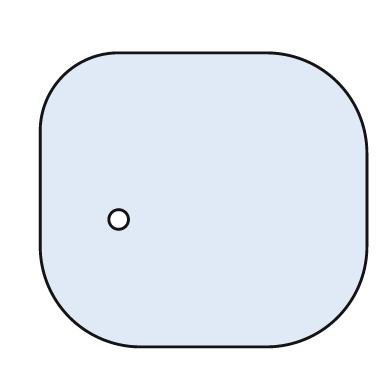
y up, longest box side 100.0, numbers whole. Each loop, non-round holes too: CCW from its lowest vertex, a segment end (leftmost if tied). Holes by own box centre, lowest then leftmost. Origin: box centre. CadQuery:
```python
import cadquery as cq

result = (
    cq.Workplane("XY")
    .moveTo(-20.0, -45.0)
    .lineTo(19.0, -45.0)
    .threePointArc((41.0, -36.0), (50.0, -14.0))
    .lineTo(50.0, 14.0)
    .threePointArc((41.0, 36.0), (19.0, 45.0))
    .lineTo(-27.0, 45.0)
    .threePointArc((-43.0, 38.0), (-50.0, 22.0))
    .lineTo(-50.0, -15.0)
    .threePointArc((-41.0, -36.0), (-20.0, -45.0))
    .close()
    .moveTo(-26.0, -6.0)
    .circle(3.0)
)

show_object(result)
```